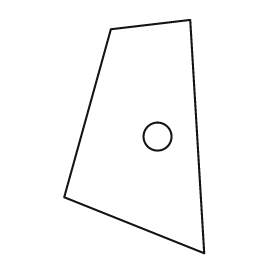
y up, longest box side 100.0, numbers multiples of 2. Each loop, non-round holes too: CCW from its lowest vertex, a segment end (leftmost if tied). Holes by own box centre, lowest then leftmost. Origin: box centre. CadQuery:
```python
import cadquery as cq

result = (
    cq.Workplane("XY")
    .moveTo(30.0, -50.0)
    .lineTo(24.0, 50.0)
    .lineTo(-10.0, 46.0)
    .lineTo(-30.0, -26.0)
    .close()
    .moveTo(10.0, 0.0)
    .circle(6.0)
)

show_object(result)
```